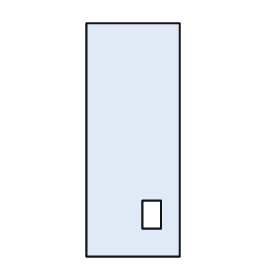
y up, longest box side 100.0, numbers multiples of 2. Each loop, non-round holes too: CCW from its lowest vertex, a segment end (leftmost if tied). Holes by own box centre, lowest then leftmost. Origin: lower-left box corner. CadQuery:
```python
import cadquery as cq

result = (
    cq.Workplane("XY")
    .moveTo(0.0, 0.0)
    .lineTo(40.0, 0.0)
    .lineTo(40.0, 100.0)
    .lineTo(0.0, 100.0)
    .close()
    .moveTo(24.0, 12.0)
    .lineTo(32.0, 12.0)
    .lineTo(32.0, 24.0)
    .lineTo(24.0, 24.0)
    .close()
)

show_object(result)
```